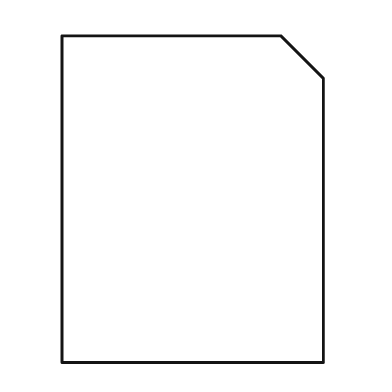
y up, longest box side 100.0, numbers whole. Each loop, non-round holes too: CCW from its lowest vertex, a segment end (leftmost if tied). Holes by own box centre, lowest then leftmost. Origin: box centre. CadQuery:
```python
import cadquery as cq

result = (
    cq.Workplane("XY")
    .moveTo(-40.0, -50.0)
    .lineTo(40.0, -50.0)
    .lineTo(40.0, 37.0)
    .lineTo(27.0, 50.0)
    .lineTo(-40.0, 50.0)
    .close()
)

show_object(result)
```